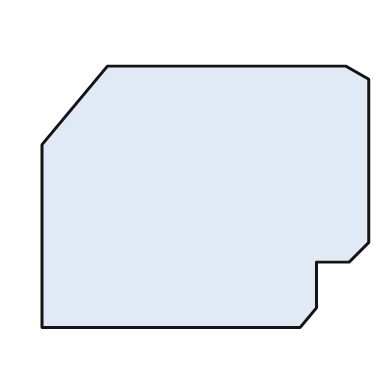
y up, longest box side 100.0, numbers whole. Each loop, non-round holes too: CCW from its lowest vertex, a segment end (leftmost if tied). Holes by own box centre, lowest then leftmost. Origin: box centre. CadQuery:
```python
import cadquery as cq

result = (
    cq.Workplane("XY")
    .moveTo(-50.0, -40.0)
    .lineTo(29.0, -40.0)
    .lineTo(34.0, -34.0)
    .lineTo(34.0, -20.0)
    .lineTo(44.0, -20.0)
    .lineTo(50.0, -14.0)
    .lineTo(50.0, 36.0)
    .lineTo(43.0, 40.0)
    .lineTo(-30.0, 40.0)
    .lineTo(-50.0, 16.0)
    .close()
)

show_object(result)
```